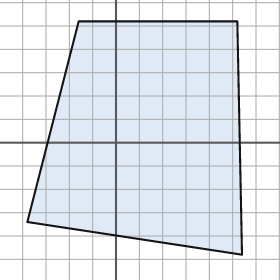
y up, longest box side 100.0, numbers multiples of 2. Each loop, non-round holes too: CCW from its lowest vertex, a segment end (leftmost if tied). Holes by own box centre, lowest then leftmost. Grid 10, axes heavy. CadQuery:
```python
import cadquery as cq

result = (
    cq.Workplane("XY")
    .moveTo(54.0, -48.0)
    .lineTo(52.0, 52.0)
    .lineTo(-16.0, 52.0)
    .lineTo(-38.0, -34.0)
    .close()
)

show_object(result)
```